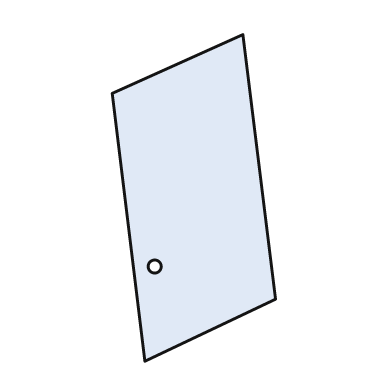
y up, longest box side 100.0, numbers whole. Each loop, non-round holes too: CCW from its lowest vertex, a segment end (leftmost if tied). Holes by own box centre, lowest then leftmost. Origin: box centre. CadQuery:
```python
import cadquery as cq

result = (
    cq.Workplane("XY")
    .moveTo(-15.0, -50.0)
    .lineTo(25.0, -31.0)
    .lineTo(15.0, 50.0)
    .lineTo(-25.0, 32.0)
    .close()
    .moveTo(-12.0, -21.0)
    .circle(2.0)
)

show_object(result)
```